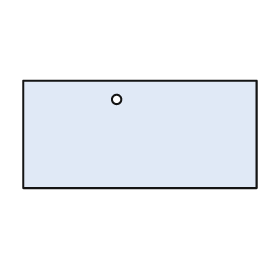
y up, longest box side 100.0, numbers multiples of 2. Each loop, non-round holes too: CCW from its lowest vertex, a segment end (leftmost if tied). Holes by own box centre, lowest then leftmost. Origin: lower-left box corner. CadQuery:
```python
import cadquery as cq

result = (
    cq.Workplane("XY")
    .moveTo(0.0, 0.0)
    .lineTo(100.0, 0.0)
    .lineTo(100.0, 46.0)
    .lineTo(0.0, 46.0)
    .close()
    .moveTo(40.0, 38.0)
    .circle(2.0)
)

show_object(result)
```